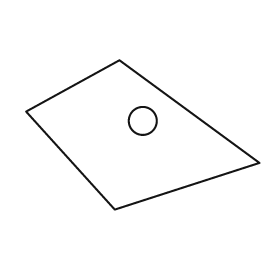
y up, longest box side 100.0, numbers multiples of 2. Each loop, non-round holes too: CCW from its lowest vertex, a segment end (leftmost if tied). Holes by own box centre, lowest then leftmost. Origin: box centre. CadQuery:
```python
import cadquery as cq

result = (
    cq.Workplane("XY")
    .moveTo(-12.0, -32.0)
    .lineTo(50.0, -12.0)
    .lineTo(-10.0, 32.0)
    .lineTo(-50.0, 10.0)
    .close()
    .moveTo(0.0, 6.0)
    .circle(6.0)
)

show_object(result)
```